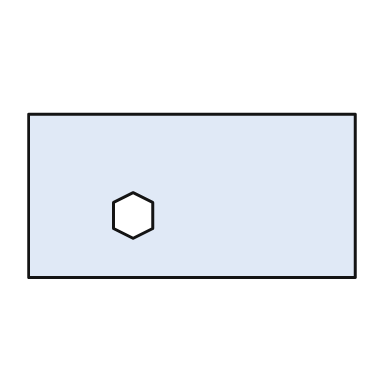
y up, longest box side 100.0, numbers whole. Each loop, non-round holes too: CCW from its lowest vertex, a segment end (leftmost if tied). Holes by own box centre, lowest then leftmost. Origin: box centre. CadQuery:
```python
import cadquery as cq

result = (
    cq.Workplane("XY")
    .moveTo(-50.0, -25.0)
    .lineTo(50.0, -25.0)
    .lineTo(50.0, 25.0)
    .lineTo(-50.0, 25.0)
    .close()
    .moveTo(-18.0, -13.0)
    .lineTo(-12.0, -10.0)
    .lineTo(-12.0, -2.0)
    .lineTo(-18.0, 1.0)
    .lineTo(-24.0, -2.0)
    .lineTo(-24.0, -10.0)
    .close()
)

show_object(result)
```